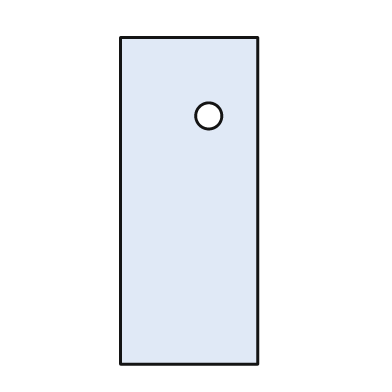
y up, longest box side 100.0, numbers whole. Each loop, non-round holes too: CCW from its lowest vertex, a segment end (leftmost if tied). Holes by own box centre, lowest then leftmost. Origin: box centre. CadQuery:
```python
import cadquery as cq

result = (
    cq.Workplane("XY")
    .moveTo(-21.0, -50.0)
    .lineTo(21.0, -50.0)
    .lineTo(21.0, 50.0)
    .lineTo(-21.0, 50.0)
    .close()
    .moveTo(6.0, 26.0)
    .circle(4.0)
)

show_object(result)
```